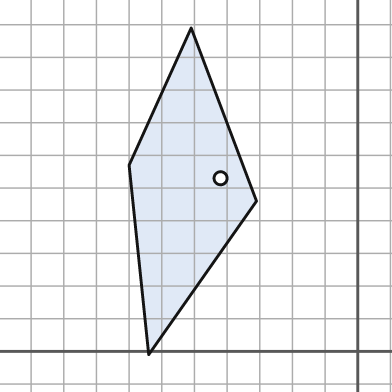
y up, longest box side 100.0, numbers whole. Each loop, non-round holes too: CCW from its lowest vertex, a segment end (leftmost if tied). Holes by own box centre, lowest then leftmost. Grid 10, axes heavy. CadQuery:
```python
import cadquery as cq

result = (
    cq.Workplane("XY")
    .moveTo(-64.0, -1.0)
    .lineTo(-31.0, 46.0)
    .lineTo(-51.0, 99.0)
    .lineTo(-70.0, 57.0)
    .close()
    .moveTo(-42.0, 53.0)
    .circle(2.0)
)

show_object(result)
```